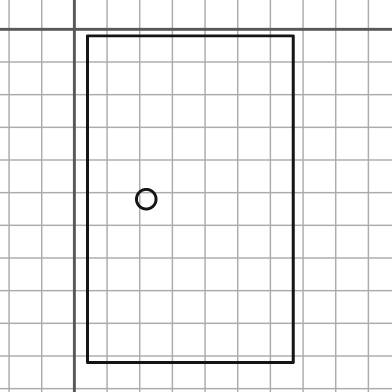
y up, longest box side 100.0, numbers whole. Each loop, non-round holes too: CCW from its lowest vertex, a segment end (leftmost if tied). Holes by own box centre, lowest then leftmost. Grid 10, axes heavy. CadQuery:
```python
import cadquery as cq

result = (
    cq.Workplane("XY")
    .moveTo(4.0, -102.0)
    .lineTo(67.0, -102.0)
    .lineTo(67.0, -2.0)
    .lineTo(4.0, -2.0)
    .close()
    .moveTo(22.0, -52.0)
    .circle(3.0)
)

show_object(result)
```